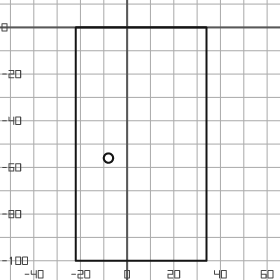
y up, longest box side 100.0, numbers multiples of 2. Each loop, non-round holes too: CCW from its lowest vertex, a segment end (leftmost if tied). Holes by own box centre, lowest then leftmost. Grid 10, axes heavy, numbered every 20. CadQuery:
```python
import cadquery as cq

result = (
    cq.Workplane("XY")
    .moveTo(-22.0, -100.0)
    .lineTo(34.0, -100.0)
    .lineTo(34.0, 0.0)
    .lineTo(-22.0, 0.0)
    .close()
    .moveTo(-8.0, -56.0)
    .circle(2.0)
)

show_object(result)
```